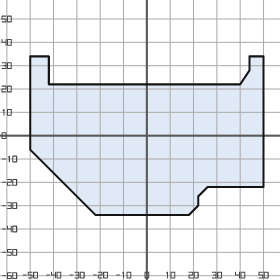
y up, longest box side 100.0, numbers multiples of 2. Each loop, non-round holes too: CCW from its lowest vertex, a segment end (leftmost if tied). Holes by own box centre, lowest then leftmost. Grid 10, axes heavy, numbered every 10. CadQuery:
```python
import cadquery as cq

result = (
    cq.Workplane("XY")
    .moveTo(-22.0, -34.0)
    .lineTo(18.0, -34.0)
    .lineTo(22.0, -30.0)
    .lineTo(22.0, -26.0)
    .lineTo(26.0, -22.0)
    .lineTo(50.0, -22.0)
    .lineTo(50.0, 34.0)
    .lineTo(44.0, 34.0)
    .lineTo(44.0, 28.0)
    .lineTo(40.0, 22.0)
    .lineTo(-42.0, 22.0)
    .lineTo(-42.0, 34.0)
    .lineTo(-50.0, 34.0)
    .lineTo(-50.0, -6.0)
    .close()
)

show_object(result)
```